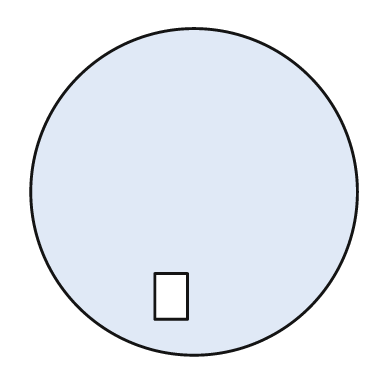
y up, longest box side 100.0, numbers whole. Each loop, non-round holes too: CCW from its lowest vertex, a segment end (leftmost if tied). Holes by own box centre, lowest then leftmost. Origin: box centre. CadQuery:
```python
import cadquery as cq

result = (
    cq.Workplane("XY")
    .moveTo(0.0, 0.0)
    .circle(50.0)
    .moveTo(-12.0, -39.0)
    .lineTo(-2.0, -39.0)
    .lineTo(-2.0, -25.0)
    .lineTo(-12.0, -25.0)
    .close()
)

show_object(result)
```